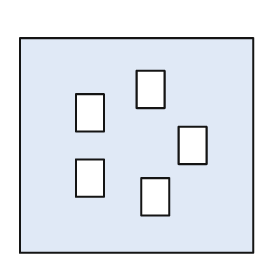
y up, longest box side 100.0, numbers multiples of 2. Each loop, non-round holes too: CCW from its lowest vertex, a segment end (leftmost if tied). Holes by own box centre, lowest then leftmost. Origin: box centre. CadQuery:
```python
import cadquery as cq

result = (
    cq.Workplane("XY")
    .moveTo(-50.0, -46.0)
    .lineTo(50.0, -46.0)
    .lineTo(50.0, 46.0)
    .lineTo(-50.0, 46.0)
    .close()
    .moveTo(2.0, -30.0)
    .lineTo(14.0, -30.0)
    .lineTo(14.0, -14.0)
    .lineTo(2.0, -14.0)
    .close()
    .moveTo(-26.0, -22.0)
    .lineTo(-14.0, -22.0)
    .lineTo(-14.0, -6.0)
    .lineTo(-26.0, -6.0)
    .close()
    .moveTo(18.0, -8.0)
    .lineTo(30.0, -8.0)
    .lineTo(30.0, 8.0)
    .lineTo(18.0, 8.0)
    .close()
    .moveTo(-26.0, 6.0)
    .lineTo(-14.0, 6.0)
    .lineTo(-14.0, 22.0)
    .lineTo(-26.0, 22.0)
    .close()
    .moveTo(0.0, 16.0)
    .lineTo(12.0, 16.0)
    .lineTo(12.0, 32.0)
    .lineTo(0.0, 32.0)
    .close()
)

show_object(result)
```